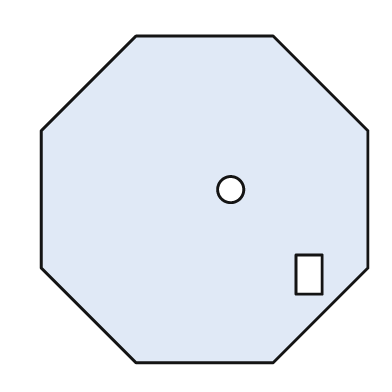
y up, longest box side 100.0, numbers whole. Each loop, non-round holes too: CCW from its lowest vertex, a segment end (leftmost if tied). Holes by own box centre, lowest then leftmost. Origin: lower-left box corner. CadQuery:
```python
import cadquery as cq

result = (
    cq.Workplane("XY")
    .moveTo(29.0, 0.0)
    .lineTo(71.0, 0.0)
    .lineTo(100.0, 29.0)
    .lineTo(100.0, 71.0)
    .lineTo(71.0, 100.0)
    .lineTo(29.0, 100.0)
    .lineTo(0.0, 71.0)
    .lineTo(0.0, 29.0)
    .close()
    .moveTo(78.0, 21.0)
    .lineTo(86.0, 21.0)
    .lineTo(86.0, 33.0)
    .lineTo(78.0, 33.0)
    .close()
    .moveTo(58.0, 53.0)
    .circle(4.0)
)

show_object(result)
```